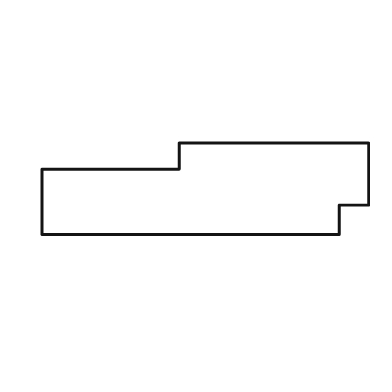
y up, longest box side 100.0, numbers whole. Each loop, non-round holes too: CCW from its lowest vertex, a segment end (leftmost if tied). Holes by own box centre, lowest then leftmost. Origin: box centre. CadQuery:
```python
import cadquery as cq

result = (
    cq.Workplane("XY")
    .moveTo(-50.0, -14.0)
    .lineTo(41.0, -14.0)
    .lineTo(41.0, -5.0)
    .lineTo(50.0, -5.0)
    .lineTo(50.0, 14.0)
    .lineTo(-8.0, 14.0)
    .lineTo(-8.0, 6.0)
    .lineTo(-50.0, 6.0)
    .close()
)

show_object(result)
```